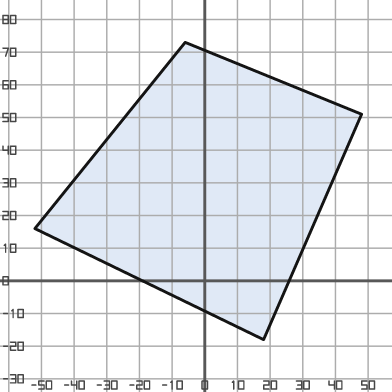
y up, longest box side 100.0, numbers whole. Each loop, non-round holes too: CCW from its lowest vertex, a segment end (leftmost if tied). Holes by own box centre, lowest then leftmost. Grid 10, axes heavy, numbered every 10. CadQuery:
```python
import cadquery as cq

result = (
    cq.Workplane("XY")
    .moveTo(18.0, -18.0)
    .lineTo(48.0, 51.0)
    .lineTo(-6.0, 73.0)
    .lineTo(-52.0, 16.0)
    .close()
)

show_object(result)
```